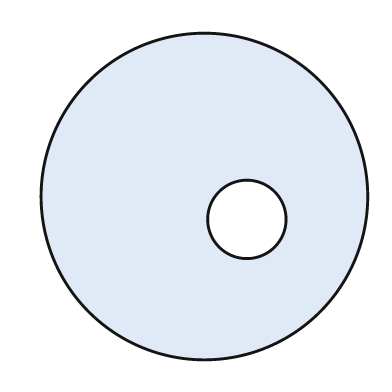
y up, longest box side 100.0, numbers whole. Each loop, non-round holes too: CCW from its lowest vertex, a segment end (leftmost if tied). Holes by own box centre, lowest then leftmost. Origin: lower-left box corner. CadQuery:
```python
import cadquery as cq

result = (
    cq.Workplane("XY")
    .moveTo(50.0, 50.0)
    .circle(50.0)
    .moveTo(63.0, 43.0)
    .circle(12.0)
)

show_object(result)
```